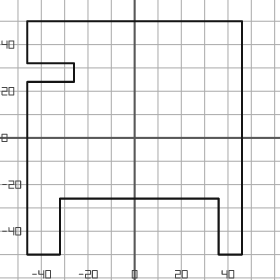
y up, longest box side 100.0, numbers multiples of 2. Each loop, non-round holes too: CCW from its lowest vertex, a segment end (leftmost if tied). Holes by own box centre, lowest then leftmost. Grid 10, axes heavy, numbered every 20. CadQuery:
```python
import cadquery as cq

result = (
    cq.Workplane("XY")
    .moveTo(-46.0, -50.0)
    .lineTo(-32.0, -50.0)
    .lineTo(-32.0, -26.0)
    .lineTo(36.0, -26.0)
    .lineTo(36.0, -50.0)
    .lineTo(46.0, -50.0)
    .lineTo(46.0, 50.0)
    .lineTo(-46.0, 50.0)
    .lineTo(-46.0, 32.0)
    .lineTo(-26.0, 32.0)
    .lineTo(-26.0, 24.0)
    .lineTo(-46.0, 24.0)
    .close()
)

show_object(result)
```